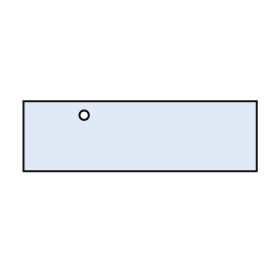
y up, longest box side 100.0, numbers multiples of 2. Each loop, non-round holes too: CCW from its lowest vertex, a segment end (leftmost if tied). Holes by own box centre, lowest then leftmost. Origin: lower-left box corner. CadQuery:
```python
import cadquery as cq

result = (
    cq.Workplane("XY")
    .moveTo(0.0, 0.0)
    .lineTo(100.0, 0.0)
    .lineTo(100.0, 30.0)
    .lineTo(0.0, 30.0)
    .close()
    .moveTo(26.0, 24.0)
    .circle(2.0)
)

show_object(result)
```